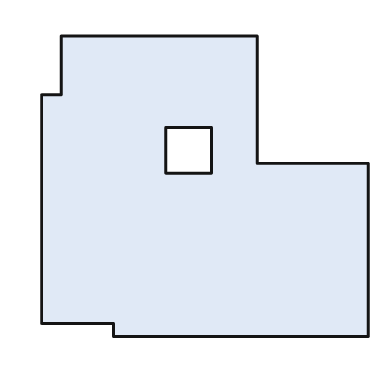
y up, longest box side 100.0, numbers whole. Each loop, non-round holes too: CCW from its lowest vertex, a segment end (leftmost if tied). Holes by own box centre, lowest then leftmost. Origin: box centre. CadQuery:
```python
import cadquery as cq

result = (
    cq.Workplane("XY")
    .moveTo(-28.0, -46.0)
    .lineTo(50.0, -46.0)
    .lineTo(50.0, 7.0)
    .lineTo(16.0, 7.0)
    .lineTo(16.0, 46.0)
    .lineTo(-44.0, 46.0)
    .lineTo(-44.0, 28.0)
    .lineTo(-50.0, 28.0)
    .lineTo(-50.0, -42.0)
    .lineTo(-28.0, -42.0)
    .close()
    .moveTo(-12.0, 4.0)
    .lineTo(2.0, 4.0)
    .lineTo(2.0, 18.0)
    .lineTo(-12.0, 18.0)
    .close()
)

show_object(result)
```